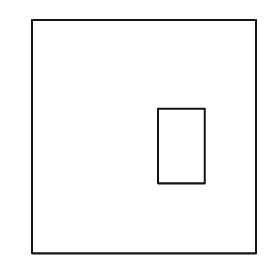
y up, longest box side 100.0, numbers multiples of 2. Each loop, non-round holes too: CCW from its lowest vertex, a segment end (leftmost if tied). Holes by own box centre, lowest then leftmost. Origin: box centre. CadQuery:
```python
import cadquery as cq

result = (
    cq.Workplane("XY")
    .moveTo(-48.0, -50.0)
    .lineTo(48.0, -50.0)
    .lineTo(48.0, 50.0)
    .lineTo(-48.0, 50.0)
    .close()
    .moveTo(6.0, -20.0)
    .lineTo(26.0, -20.0)
    .lineTo(26.0, 12.0)
    .lineTo(6.0, 12.0)
    .close()
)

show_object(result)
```